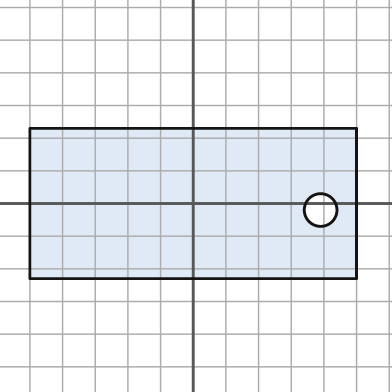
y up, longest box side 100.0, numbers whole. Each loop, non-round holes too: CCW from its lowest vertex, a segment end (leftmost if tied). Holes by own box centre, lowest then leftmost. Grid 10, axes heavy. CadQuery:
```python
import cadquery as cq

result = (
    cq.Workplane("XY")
    .moveTo(-50.0, -23.0)
    .lineTo(50.0, -23.0)
    .lineTo(50.0, 23.0)
    .lineTo(-50.0, 23.0)
    .close()
    .moveTo(39.0, -2.0)
    .circle(5.0)
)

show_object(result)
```